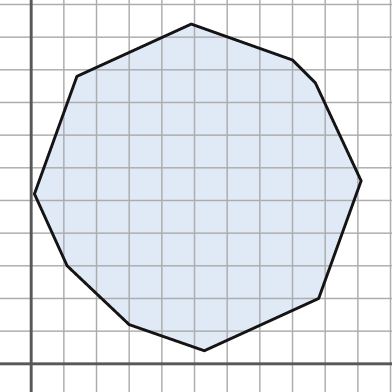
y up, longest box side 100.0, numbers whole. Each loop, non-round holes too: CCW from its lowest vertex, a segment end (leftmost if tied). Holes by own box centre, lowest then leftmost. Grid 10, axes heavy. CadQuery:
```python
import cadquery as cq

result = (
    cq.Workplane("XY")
    .moveTo(53.0, 4.0)
    .lineTo(88.0, 20.0)
    .lineTo(101.0, 56.0)
    .lineTo(87.0, 86.0)
    .lineTo(80.0, 93.0)
    .lineTo(49.0, 104.0)
    .lineTo(14.0, 88.0)
    .lineTo(1.0, 52.0)
    .lineTo(11.0, 30.0)
    .lineTo(30.0, 12.0)
    .close()
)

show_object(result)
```